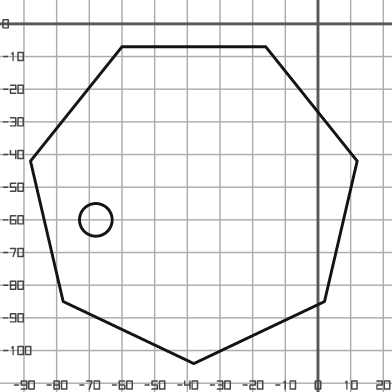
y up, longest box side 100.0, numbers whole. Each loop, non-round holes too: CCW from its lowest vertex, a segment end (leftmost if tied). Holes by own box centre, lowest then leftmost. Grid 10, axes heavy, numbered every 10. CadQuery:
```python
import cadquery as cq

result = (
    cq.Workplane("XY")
    .moveTo(-38.0, -104.0)
    .lineTo(2.0, -85.0)
    .lineTo(12.0, -42.0)
    .lineTo(-16.0, -7.0)
    .lineTo(-60.0, -7.0)
    .lineTo(-88.0, -42.0)
    .lineTo(-78.0, -85.0)
    .close()
    .moveTo(-68.0, -60.0)
    .circle(5.0)
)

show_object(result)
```